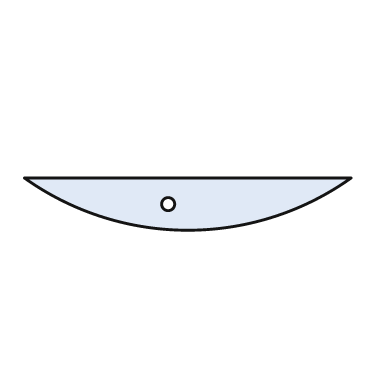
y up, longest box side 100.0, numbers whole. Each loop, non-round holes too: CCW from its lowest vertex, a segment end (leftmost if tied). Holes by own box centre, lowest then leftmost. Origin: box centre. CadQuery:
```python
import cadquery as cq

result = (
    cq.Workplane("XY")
    .moveTo(-50.0, 8.0)
    .threePointArc((0.0, -8.0), (50.0, 8.0))
    .close()
    .moveTo(-6.0, 0.0)
    .circle(2.0)
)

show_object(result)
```